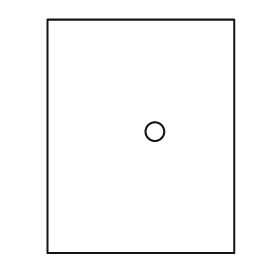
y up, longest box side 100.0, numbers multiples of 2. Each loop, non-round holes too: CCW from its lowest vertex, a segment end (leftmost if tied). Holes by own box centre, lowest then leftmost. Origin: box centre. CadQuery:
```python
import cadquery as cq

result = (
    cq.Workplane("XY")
    .moveTo(-40.0, -50.0)
    .lineTo(40.0, -50.0)
    .lineTo(40.0, 50.0)
    .lineTo(-40.0, 50.0)
    .close()
    .moveTo(6.0, 2.0)
    .circle(4.0)
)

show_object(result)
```